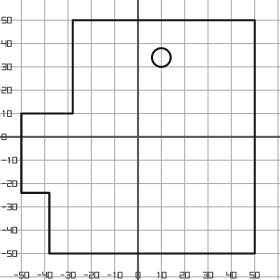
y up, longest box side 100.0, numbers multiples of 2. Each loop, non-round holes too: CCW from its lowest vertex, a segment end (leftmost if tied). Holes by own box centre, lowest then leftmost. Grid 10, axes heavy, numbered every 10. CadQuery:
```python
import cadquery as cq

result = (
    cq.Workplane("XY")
    .moveTo(-38.0, -50.0)
    .lineTo(50.0, -50.0)
    .lineTo(50.0, 50.0)
    .lineTo(-28.0, 50.0)
    .lineTo(-28.0, 10.0)
    .lineTo(-50.0, 10.0)
    .lineTo(-50.0, -24.0)
    .lineTo(-38.0, -24.0)
    .close()
    .moveTo(10.0, 34.0)
    .circle(4.0)
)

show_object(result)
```